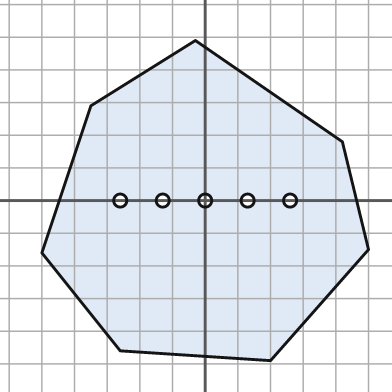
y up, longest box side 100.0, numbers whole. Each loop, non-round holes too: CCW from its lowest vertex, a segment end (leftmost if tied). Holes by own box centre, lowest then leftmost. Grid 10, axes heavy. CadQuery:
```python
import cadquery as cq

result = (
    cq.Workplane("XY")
    .moveTo(20.0, -49.0)
    .lineTo(50.0, -15.0)
    .lineTo(42.0, 18.0)
    .lineTo(-3.0, 49.0)
    .lineTo(-35.0, 29.0)
    .lineTo(-50.0, -16.0)
    .lineTo(-26.0, -46.0)
    .close()
    .moveTo(-26.0, 0.0)
    .circle(2.0)
    .moveTo(-13.0, 0.0)
    .circle(2.0)
    .moveTo(0.0, 0.0)
    .circle(2.0)
    .moveTo(13.0, 0.0)
    .circle(2.0)
    .moveTo(26.0, 0.0)
    .circle(2.0)
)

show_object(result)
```